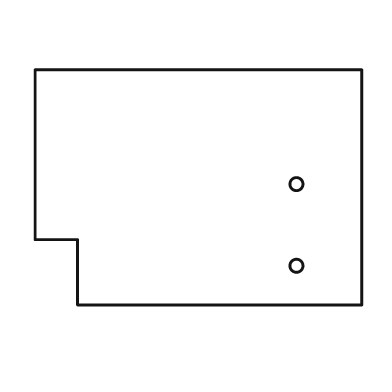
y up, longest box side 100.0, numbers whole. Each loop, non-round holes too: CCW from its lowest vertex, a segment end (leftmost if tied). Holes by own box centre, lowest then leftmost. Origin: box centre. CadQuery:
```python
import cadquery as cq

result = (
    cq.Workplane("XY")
    .moveTo(-37.0, -36.0)
    .lineTo(50.0, -36.0)
    .lineTo(50.0, 36.0)
    .lineTo(-50.0, 36.0)
    .lineTo(-50.0, -16.0)
    .lineTo(-37.0, -16.0)
    .close()
    .moveTo(30.0, -24.0)
    .circle(2.0)
    .moveTo(30.0, 1.0)
    .circle(2.0)
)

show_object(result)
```